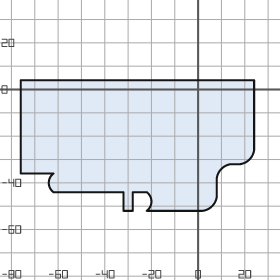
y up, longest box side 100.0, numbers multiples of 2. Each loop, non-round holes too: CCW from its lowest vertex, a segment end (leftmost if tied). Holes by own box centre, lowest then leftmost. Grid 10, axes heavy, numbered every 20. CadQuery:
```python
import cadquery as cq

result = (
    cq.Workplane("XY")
    .moveTo(-32.0, -52.0)
    .lineTo(-28.0, -52.0)
    .lineTo(-28.0, -44.0)
    .lineTo(-22.0, -44.0)
    .threePointArc((-20.0, -48.0), (-22.0, -52.0))
    .lineTo(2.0, -52.0)
    .threePointArc((6.0, -50.0), (8.0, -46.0))
    .lineTo(8.0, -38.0)
    .threePointArc((10.0, -34.0), (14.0, -32.0))
    .lineTo(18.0, -32.0)
    .threePointArc((22.0, -30.0), (24.0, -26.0))
    .lineTo(24.0, 4.0)
    .lineTo(-76.0, 4.0)
    .lineTo(-76.0, -36.0)
    .lineTo(-62.0, -36.0)
    .threePointArc((-64.0, -40.0), (-62.0, -44.0))
    .lineTo(-32.0, -44.0)
    .close()
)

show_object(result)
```